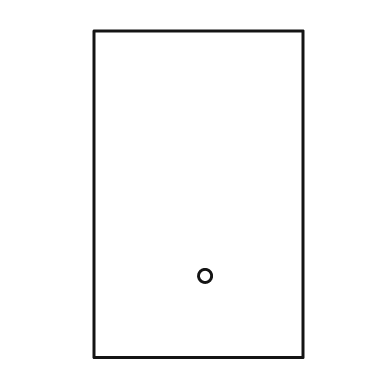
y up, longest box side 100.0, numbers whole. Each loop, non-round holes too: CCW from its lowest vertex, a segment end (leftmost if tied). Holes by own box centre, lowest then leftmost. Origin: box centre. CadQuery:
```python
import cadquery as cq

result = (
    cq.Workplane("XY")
    .moveTo(-32.0, -50.0)
    .lineTo(32.0, -50.0)
    .lineTo(32.0, 50.0)
    .lineTo(-32.0, 50.0)
    .close()
    .moveTo(2.0, -25.0)
    .circle(2.0)
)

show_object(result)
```